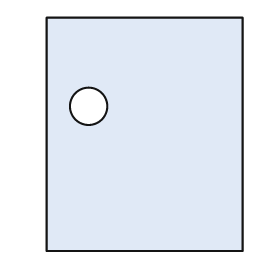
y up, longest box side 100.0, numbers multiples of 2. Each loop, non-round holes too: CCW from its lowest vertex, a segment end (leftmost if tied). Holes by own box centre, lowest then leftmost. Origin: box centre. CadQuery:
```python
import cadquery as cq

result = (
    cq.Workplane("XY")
    .moveTo(-42.0, -50.0)
    .lineTo(42.0, -50.0)
    .lineTo(42.0, 50.0)
    .lineTo(-42.0, 50.0)
    .close()
    .moveTo(-24.0, 12.0)
    .circle(8.0)
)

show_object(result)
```